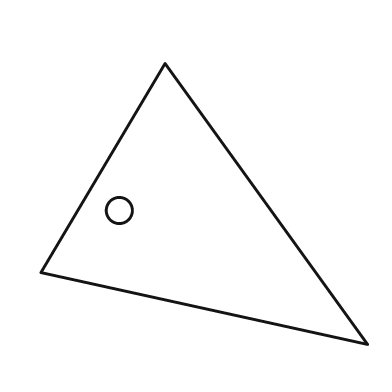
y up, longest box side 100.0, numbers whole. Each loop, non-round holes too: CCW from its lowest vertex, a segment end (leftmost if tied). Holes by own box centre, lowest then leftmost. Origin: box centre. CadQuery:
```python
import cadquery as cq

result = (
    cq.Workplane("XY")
    .moveTo(50.0, -43.0)
    .lineTo(-12.0, 43.0)
    .lineTo(-50.0, -21.0)
    .close()
    .moveTo(-26.0, -2.0)
    .circle(4.0)
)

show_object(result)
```